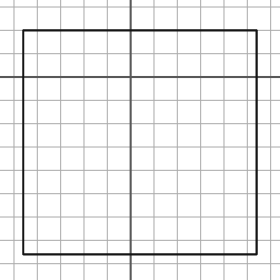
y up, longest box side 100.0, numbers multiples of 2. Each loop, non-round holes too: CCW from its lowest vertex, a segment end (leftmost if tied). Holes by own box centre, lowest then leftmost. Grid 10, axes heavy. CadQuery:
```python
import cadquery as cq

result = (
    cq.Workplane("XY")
    .moveTo(-46.0, -76.0)
    .lineTo(54.0, -76.0)
    .lineTo(54.0, 20.0)
    .lineTo(-46.0, 20.0)
    .close()
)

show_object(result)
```